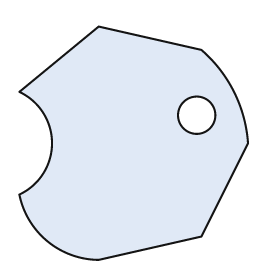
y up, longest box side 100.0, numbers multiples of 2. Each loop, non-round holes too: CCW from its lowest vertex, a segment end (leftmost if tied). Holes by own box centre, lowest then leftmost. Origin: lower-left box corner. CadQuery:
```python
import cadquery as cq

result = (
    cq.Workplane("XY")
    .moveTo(34.0, 0.0)
    .lineTo(78.0, 10.0)
    .lineTo(98.0, 50.0)
    .threePointArc((92.0, 72.0), (78.0, 90.0))
    .lineTo(34.0, 100.0)
    .lineTo(0.0, 72.0)
    .threePointArc((14.0, 50.0), (0.0, 28.0))
    .threePointArc((12.0, 8.0), (34.0, 0.0))
    .close()
    .moveTo(76.0, 62.0)
    .circle(8.0)
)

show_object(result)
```